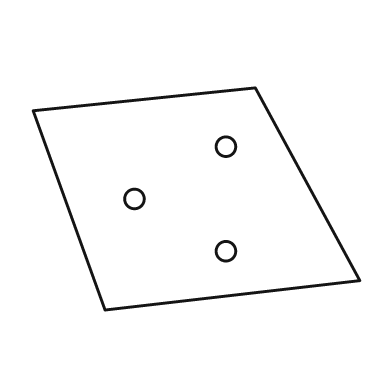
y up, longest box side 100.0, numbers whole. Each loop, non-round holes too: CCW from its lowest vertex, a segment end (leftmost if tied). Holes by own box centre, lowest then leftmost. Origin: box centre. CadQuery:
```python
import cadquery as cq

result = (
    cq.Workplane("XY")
    .moveTo(-28.0, -34.0)
    .lineTo(50.0, -25.0)
    .lineTo(18.0, 34.0)
    .lineTo(-50.0, 27.0)
    .close()
    .moveTo(9.0, -16.0)
    .circle(3.0)
    .moveTo(-19.0, 0.0)
    .circle(3.0)
    .moveTo(9.0, 16.0)
    .circle(3.0)
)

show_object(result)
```